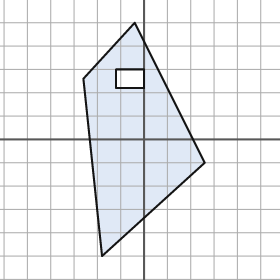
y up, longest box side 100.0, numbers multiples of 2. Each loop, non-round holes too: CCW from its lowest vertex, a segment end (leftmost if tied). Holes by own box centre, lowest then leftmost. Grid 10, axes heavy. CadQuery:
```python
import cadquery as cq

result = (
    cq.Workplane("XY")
    .moveTo(-18.0, -50.0)
    .lineTo(26.0, -10.0)
    .lineTo(-4.0, 50.0)
    .lineTo(-26.0, 26.0)
    .close()
    .moveTo(-12.0, 22.0)
    .lineTo(0.0, 22.0)
    .lineTo(0.0, 30.0)
    .lineTo(-12.0, 30.0)
    .close()
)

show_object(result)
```